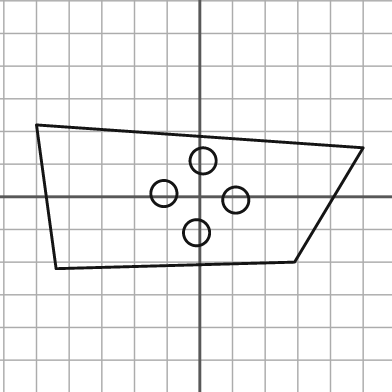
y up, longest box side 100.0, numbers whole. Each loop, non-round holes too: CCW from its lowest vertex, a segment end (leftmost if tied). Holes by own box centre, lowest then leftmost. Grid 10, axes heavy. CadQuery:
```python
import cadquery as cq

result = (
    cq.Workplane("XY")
    .moveTo(-44.0, -22.0)
    .lineTo(29.0, -20.0)
    .lineTo(50.0, 15.0)
    .lineTo(-50.0, 22.0)
    .close()
    .moveTo(-1.0, -11.0)
    .circle(4.0)
    .moveTo(11.0, -1.0)
    .circle(4.0)
    .moveTo(-11.0, 1.0)
    .circle(4.0)
    .moveTo(1.0, 11.0)
    .circle(4.0)
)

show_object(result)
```